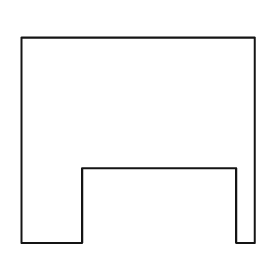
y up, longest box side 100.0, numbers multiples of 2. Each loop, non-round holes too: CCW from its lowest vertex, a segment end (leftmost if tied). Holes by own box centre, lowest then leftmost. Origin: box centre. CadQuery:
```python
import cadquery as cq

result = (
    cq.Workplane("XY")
    .moveTo(-50.0, -44.0)
    .lineTo(-24.0, -44.0)
    .lineTo(-24.0, -12.0)
    .lineTo(42.0, -12.0)
    .lineTo(42.0, -44.0)
    .lineTo(50.0, -44.0)
    .lineTo(50.0, 44.0)
    .lineTo(-50.0, 44.0)
    .close()
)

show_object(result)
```